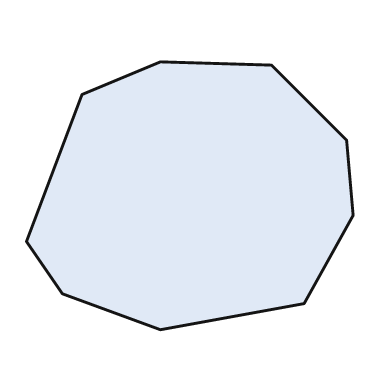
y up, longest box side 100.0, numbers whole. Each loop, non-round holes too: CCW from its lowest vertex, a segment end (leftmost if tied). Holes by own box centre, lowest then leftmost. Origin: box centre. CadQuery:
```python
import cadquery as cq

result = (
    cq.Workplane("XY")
    .moveTo(-9.0, -41.0)
    .lineTo(35.0, -33.0)
    .lineTo(50.0, -6.0)
    .lineTo(48.0, 17.0)
    .lineTo(25.0, 40.0)
    .lineTo(-9.0, 41.0)
    .lineTo(-33.0, 31.0)
    .lineTo(-50.0, -14.0)
    .lineTo(-39.0, -30.0)
    .close()
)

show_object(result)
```